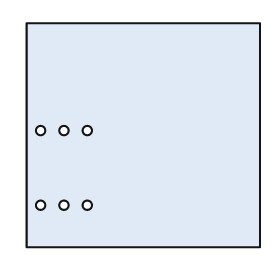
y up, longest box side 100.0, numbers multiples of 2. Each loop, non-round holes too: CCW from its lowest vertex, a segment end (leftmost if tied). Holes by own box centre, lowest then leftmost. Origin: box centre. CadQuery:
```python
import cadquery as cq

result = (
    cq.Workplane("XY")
    .moveTo(-50.0, -48.0)
    .lineTo(50.0, -48.0)
    .lineTo(50.0, 48.0)
    .lineTo(-50.0, 48.0)
    .close()
    .moveTo(-44.0, -30.0)
    .circle(2.0)
    .moveTo(-34.0, -30.0)
    .circle(2.0)
    .moveTo(-24.0, -30.0)
    .circle(2.0)
    .moveTo(-44.0, 2.0)
    .circle(2.0)
    .moveTo(-34.0, 2.0)
    .circle(2.0)
    .moveTo(-24.0, 2.0)
    .circle(2.0)
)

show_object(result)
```